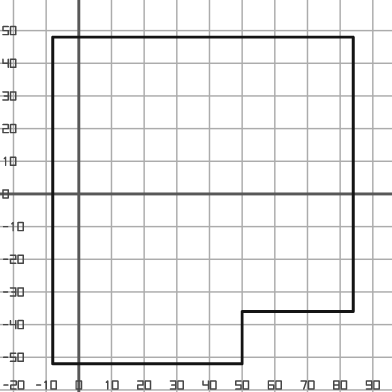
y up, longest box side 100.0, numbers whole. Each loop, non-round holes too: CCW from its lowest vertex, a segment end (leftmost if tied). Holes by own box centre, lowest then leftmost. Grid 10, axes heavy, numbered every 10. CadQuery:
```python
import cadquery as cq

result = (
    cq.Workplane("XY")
    .moveTo(-8.0, -52.0)
    .lineTo(50.0, -52.0)
    .lineTo(50.0, -36.0)
    .lineTo(84.0, -36.0)
    .lineTo(84.0, 48.0)
    .lineTo(-8.0, 48.0)
    .close()
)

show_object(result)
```